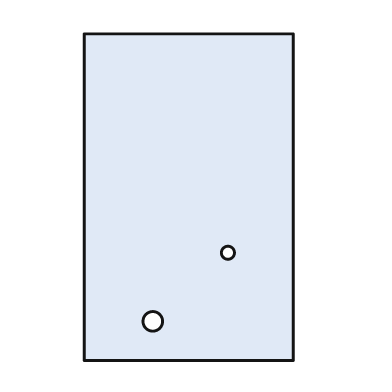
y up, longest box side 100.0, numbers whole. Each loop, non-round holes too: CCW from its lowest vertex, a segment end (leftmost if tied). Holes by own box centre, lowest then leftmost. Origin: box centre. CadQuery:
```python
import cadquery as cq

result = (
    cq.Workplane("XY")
    .moveTo(-32.0, -50.0)
    .lineTo(32.0, -50.0)
    .lineTo(32.0, 50.0)
    .lineTo(-32.0, 50.0)
    .close()
    .moveTo(-11.0, -38.0)
    .circle(3.0)
    .moveTo(12.0, -17.0)
    .circle(2.0)
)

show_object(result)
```